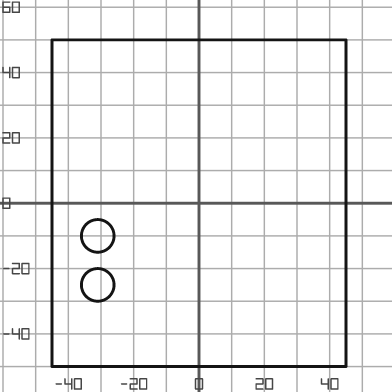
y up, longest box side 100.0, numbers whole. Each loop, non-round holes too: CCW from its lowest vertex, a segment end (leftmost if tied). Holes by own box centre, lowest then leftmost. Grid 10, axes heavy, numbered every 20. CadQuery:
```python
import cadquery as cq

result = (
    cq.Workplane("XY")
    .moveTo(-45.0, -50.0)
    .lineTo(45.0, -50.0)
    .lineTo(45.0, 50.0)
    .lineTo(-45.0, 50.0)
    .close()
    .moveTo(-31.0, -25.0)
    .circle(5.0)
    .moveTo(-31.0, -10.0)
    .circle(5.0)
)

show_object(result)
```